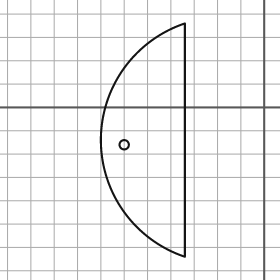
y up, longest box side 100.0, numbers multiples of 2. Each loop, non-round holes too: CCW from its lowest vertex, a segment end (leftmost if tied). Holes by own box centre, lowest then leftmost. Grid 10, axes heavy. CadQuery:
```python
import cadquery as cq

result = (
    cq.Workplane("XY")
    .moveTo(-34.0, -64.0)
    .lineTo(-34.0, 36.0)
    .threePointArc((-70.0, -14.0), (-34.0, -64.0))
    .close()
    .moveTo(-60.0, -16.0)
    .circle(2.0)
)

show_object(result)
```